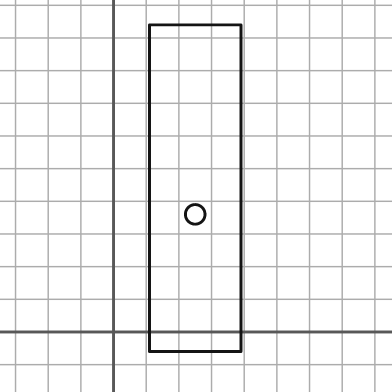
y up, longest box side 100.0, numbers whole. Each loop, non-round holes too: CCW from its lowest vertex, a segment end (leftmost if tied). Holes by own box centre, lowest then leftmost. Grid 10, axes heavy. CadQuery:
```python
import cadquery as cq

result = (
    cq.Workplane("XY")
    .moveTo(11.0, -6.0)
    .lineTo(39.0, -6.0)
    .lineTo(39.0, 94.0)
    .lineTo(11.0, 94.0)
    .close()
    .moveTo(25.0, 36.0)
    .circle(3.0)
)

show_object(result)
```